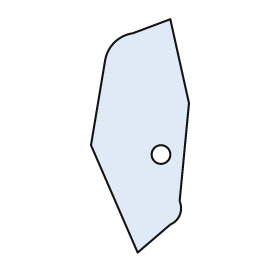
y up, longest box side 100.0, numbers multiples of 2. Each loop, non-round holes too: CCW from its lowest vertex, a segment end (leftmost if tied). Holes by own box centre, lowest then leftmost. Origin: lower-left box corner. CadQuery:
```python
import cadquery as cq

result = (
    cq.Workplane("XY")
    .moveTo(20.0, 0.0)
    .lineTo(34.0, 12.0)
    .threePointArc((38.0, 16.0), (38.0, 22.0))
    .lineTo(42.0, 64.0)
    .lineTo(34.0, 100.0)
    .lineTo(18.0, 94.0)
    .threePointArc((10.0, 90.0), (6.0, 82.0))
    .lineTo(0.0, 46.0)
    .close()
    .moveTo(30.0, 42.0)
    .circle(4.0)
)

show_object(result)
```